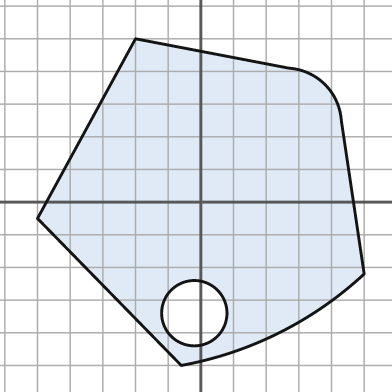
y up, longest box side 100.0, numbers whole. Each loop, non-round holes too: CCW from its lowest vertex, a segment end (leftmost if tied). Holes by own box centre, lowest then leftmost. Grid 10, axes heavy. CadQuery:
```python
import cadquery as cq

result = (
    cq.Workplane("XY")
    .moveTo(-6.0, -50.0)
    .threePointArc((24.0, -40.0), (50.0, -22.0))
    .lineTo(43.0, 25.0)
    .threePointArc((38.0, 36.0), (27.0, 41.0))
    .lineTo(-20.0, 50.0)
    .lineTo(-50.0, -5.0)
    .close()
    .moveTo(-2.0, -34.0)
    .circle(10.0)
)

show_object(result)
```